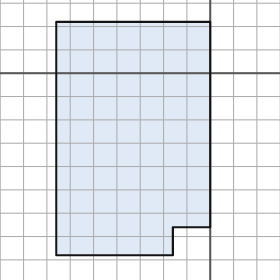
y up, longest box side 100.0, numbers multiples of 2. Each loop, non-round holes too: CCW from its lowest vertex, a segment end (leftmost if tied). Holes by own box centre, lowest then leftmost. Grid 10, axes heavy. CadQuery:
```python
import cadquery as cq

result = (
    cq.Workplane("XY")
    .moveTo(-66.0, -78.0)
    .lineTo(-16.0, -78.0)
    .lineTo(-16.0, -66.0)
    .lineTo(0.0, -66.0)
    .lineTo(0.0, 22.0)
    .lineTo(-66.0, 22.0)
    .close()
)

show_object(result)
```